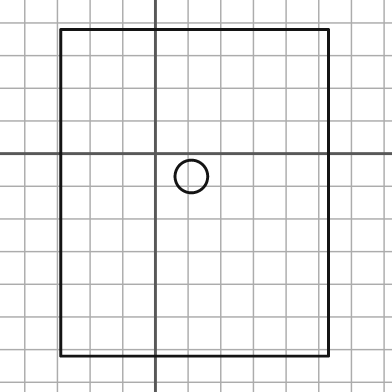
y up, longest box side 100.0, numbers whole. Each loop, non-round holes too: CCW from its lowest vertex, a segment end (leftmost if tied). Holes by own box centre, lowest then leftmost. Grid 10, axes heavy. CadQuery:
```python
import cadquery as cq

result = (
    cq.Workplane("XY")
    .moveTo(-29.0, -62.0)
    .lineTo(53.0, -62.0)
    .lineTo(53.0, 38.0)
    .lineTo(-29.0, 38.0)
    .close()
    .moveTo(11.0, -7.0)
    .circle(5.0)
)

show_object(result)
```